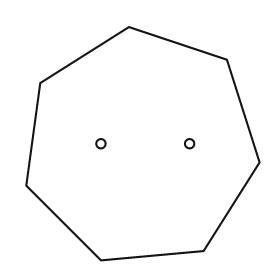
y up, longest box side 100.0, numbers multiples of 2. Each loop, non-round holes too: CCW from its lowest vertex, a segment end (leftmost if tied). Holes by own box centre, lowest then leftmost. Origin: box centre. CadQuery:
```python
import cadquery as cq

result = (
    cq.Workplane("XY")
    .moveTo(-18.0, -50.0)
    .lineTo(26.0, -46.0)
    .lineTo(50.0, -8.0)
    .lineTo(36.0, 36.0)
    .lineTo(-6.0, 50.0)
    .lineTo(-44.0, 26.0)
    .lineTo(-50.0, -18.0)
    .close()
    .moveTo(-18.0, 0.0)
    .circle(2.0)
    .moveTo(20.0, 0.0)
    .circle(2.0)
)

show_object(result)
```